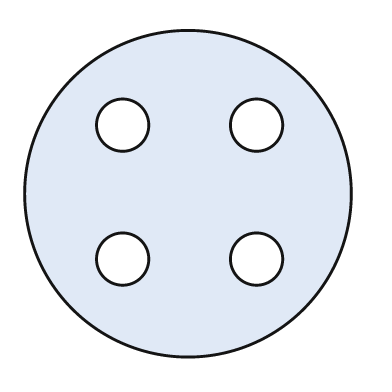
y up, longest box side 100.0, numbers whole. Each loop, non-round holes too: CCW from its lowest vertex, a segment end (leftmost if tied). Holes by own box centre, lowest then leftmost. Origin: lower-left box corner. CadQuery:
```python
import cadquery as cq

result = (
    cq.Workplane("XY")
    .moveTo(50.0, 50.0)
    .circle(50.0)
    .moveTo(30.0, 30.0)
    .circle(8.0)
    .moveTo(71.0, 30.0)
    .circle(8.0)
    .moveTo(30.0, 71.0)
    .circle(8.0)
    .moveTo(71.0, 71.0)
    .circle(8.0)
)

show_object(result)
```